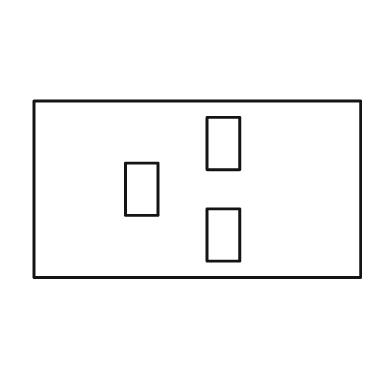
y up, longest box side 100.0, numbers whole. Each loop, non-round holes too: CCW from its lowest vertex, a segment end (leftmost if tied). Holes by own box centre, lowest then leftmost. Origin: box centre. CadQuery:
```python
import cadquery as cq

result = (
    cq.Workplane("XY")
    .moveTo(-50.0, -27.0)
    .lineTo(50.0, -27.0)
    .lineTo(50.0, 27.0)
    .lineTo(-50.0, 27.0)
    .close()
    .moveTo(3.0, -22.0)
    .lineTo(13.0, -22.0)
    .lineTo(13.0, -6.0)
    .lineTo(3.0, -6.0)
    .close()
    .moveTo(-22.0, -8.0)
    .lineTo(-12.0, -8.0)
    .lineTo(-12.0, 8.0)
    .lineTo(-22.0, 8.0)
    .close()
    .moveTo(3.0, 6.0)
    .lineTo(13.0, 6.0)
    .lineTo(13.0, 22.0)
    .lineTo(3.0, 22.0)
    .close()
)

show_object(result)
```